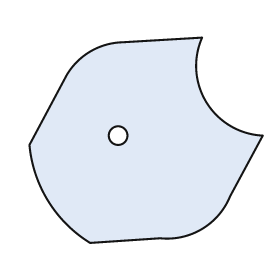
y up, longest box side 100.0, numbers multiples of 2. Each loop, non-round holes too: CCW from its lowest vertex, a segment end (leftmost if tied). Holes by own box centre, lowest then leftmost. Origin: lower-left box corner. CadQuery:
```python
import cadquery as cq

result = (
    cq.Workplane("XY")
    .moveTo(26.0, 0.0)
    .lineTo(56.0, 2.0)
    .threePointArc((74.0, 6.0), (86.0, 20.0))
    .lineTo(100.0, 46.0)
    .threePointArc((76.0, 60.0), (74.0, 88.0))
    .lineTo(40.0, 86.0)
    .threePointArc((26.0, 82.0), (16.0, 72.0))
    .lineTo(0.0, 42.0)
    .threePointArc((8.0, 18.0), (26.0, 0.0))
    .close()
    .moveTo(38.0, 46.0)
    .circle(4.0)
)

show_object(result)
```